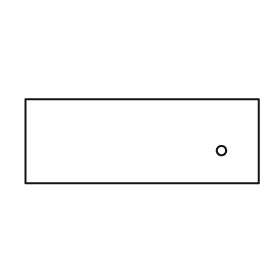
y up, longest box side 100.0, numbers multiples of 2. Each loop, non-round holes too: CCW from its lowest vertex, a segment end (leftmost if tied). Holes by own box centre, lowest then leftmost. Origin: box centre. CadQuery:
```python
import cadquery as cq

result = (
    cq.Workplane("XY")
    .moveTo(-50.0, -18.0)
    .lineTo(50.0, -18.0)
    .lineTo(50.0, 18.0)
    .lineTo(-50.0, 18.0)
    .close()
    .moveTo(34.0, -4.0)
    .circle(2.0)
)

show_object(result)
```